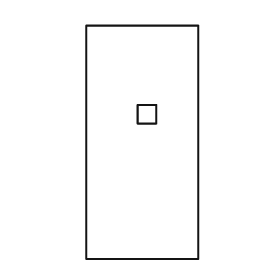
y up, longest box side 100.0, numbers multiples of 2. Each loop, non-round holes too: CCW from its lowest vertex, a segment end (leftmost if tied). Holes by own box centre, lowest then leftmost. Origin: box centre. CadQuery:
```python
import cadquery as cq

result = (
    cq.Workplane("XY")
    .moveTo(-24.0, -50.0)
    .lineTo(24.0, -50.0)
    .lineTo(24.0, 50.0)
    .lineTo(-24.0, 50.0)
    .close()
    .moveTo(-2.0, 8.0)
    .lineTo(6.0, 8.0)
    .lineTo(6.0, 16.0)
    .lineTo(-2.0, 16.0)
    .close()
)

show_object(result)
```